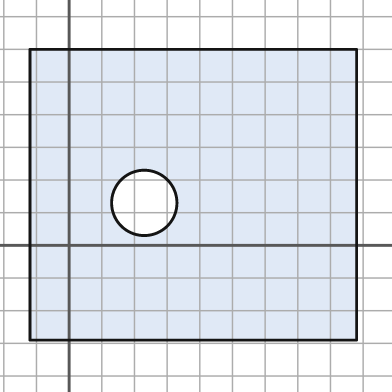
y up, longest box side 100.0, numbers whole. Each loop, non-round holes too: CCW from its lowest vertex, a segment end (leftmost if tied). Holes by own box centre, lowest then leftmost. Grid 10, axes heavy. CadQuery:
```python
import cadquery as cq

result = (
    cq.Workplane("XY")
    .moveTo(-12.0, -29.0)
    .lineTo(88.0, -29.0)
    .lineTo(88.0, 60.0)
    .lineTo(-12.0, 60.0)
    .close()
    .moveTo(23.0, 13.0)
    .circle(10.0)
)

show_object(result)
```